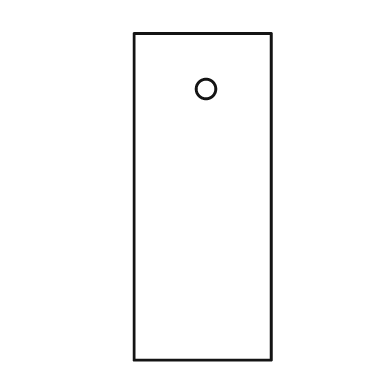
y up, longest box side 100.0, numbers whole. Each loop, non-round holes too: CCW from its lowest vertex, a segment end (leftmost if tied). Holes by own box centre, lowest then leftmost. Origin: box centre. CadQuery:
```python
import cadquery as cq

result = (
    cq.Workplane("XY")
    .moveTo(-21.0, -50.0)
    .lineTo(21.0, -50.0)
    .lineTo(21.0, 50.0)
    .lineTo(-21.0, 50.0)
    .close()
    .moveTo(1.0, 33.0)
    .circle(3.0)
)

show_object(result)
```